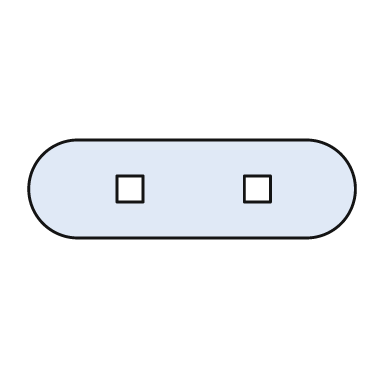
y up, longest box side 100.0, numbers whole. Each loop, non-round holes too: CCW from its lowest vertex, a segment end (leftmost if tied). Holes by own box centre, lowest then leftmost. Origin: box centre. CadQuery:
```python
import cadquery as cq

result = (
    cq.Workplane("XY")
    .moveTo(-35.0, -15.0)
    .lineTo(35.0, -15.0)
    .threePointArc((50.0, 0.0), (35.0, 15.0))
    .lineTo(-35.0, 15.0)
    .threePointArc((-50.0, 0.0), (-35.0, -15.0))
    .close()
    .moveTo(-23.0, -4.0)
    .lineTo(-15.0, -4.0)
    .lineTo(-15.0, 4.0)
    .lineTo(-23.0, 4.0)
    .close()
    .moveTo(16.0, -4.0)
    .lineTo(24.0, -4.0)
    .lineTo(24.0, 4.0)
    .lineTo(16.0, 4.0)
    .close()
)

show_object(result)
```